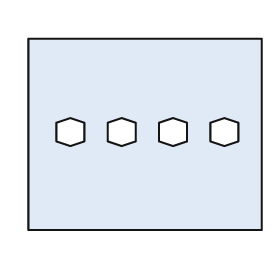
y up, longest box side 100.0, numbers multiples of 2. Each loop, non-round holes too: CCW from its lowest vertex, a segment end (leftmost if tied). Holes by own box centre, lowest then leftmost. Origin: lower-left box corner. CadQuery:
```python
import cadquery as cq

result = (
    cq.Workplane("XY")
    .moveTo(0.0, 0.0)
    .lineTo(100.0, 0.0)
    .lineTo(100.0, 82.0)
    .lineTo(0.0, 82.0)
    .close()
    .moveTo(18.0, 36.0)
    .lineTo(24.0, 38.0)
    .lineTo(24.0, 46.0)
    .lineTo(18.0, 48.0)
    .lineTo(12.0, 46.0)
    .lineTo(12.0, 38.0)
    .close()
    .moveTo(40.0, 36.0)
    .lineTo(46.0, 38.0)
    .lineTo(46.0, 46.0)
    .lineTo(40.0, 48.0)
    .lineTo(34.0, 46.0)
    .lineTo(34.0, 38.0)
    .close()
    .moveTo(62.0, 36.0)
    .lineTo(68.0, 38.0)
    .lineTo(68.0, 46.0)
    .lineTo(62.0, 48.0)
    .lineTo(56.0, 46.0)
    .lineTo(56.0, 38.0)
    .close()
    .moveTo(84.0, 36.0)
    .lineTo(90.0, 38.0)
    .lineTo(90.0, 46.0)
    .lineTo(84.0, 48.0)
    .lineTo(78.0, 46.0)
    .lineTo(78.0, 38.0)
    .close()
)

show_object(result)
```